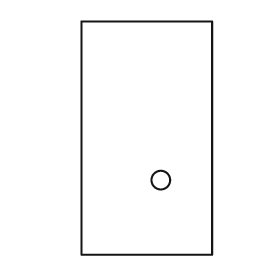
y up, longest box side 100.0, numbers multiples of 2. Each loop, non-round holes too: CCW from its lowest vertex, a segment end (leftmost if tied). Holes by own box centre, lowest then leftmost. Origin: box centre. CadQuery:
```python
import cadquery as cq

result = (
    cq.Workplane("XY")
    .moveTo(-28.0, -50.0)
    .lineTo(28.0, -50.0)
    .lineTo(28.0, 50.0)
    .lineTo(-28.0, 50.0)
    .close()
    .moveTo(6.0, -18.0)
    .circle(4.0)
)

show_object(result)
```